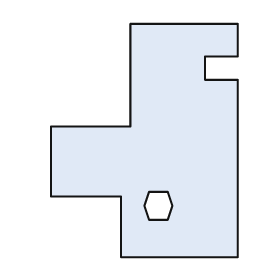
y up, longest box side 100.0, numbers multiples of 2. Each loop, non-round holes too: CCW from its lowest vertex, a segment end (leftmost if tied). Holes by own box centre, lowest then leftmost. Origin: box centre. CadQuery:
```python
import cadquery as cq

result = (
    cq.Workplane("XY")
    .moveTo(-10.0, -50.0)
    .lineTo(40.0, -50.0)
    .lineTo(40.0, 26.0)
    .lineTo(26.0, 26.0)
    .lineTo(26.0, 36.0)
    .lineTo(40.0, 36.0)
    .lineTo(40.0, 50.0)
    .lineTo(-6.0, 50.0)
    .lineTo(-6.0, 6.0)
    .lineTo(-40.0, 6.0)
    .lineTo(-40.0, -24.0)
    .lineTo(-10.0, -24.0)
    .close()
    .moveTo(2.0, -34.0)
    .lineTo(10.0, -34.0)
    .lineTo(12.0, -28.0)
    .lineTo(10.0, -22.0)
    .lineTo(2.0, -22.0)
    .lineTo(0.0, -28.0)
    .close()
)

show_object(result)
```